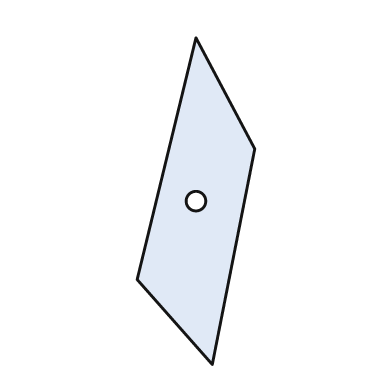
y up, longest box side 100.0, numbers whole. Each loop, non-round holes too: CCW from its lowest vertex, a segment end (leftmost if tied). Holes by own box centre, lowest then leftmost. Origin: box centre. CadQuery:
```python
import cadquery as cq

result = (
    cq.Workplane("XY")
    .moveTo(5.0, -50.0)
    .lineTo(18.0, 16.0)
    .lineTo(0.0, 50.0)
    .lineTo(-18.0, -24.0)
    .close()
    .moveTo(0.0, 0.0)
    .circle(3.0)
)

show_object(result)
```